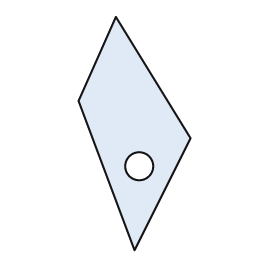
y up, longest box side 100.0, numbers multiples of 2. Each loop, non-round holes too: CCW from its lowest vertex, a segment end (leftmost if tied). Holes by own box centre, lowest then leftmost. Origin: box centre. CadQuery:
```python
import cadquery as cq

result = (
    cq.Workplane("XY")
    .moveTo(0.0, -50.0)
    .lineTo(24.0, -2.0)
    .lineTo(-8.0, 50.0)
    .lineTo(-24.0, 14.0)
    .close()
    .moveTo(2.0, -14.0)
    .circle(6.0)
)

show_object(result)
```